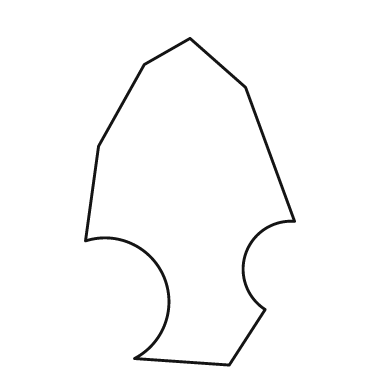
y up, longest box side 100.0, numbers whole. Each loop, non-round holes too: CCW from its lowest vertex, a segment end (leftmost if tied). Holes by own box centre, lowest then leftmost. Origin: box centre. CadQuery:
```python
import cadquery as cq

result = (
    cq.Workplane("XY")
    .moveTo(12.0, -50.0)
    .lineTo(23.0, -33.0)
    .threePointArc((17.0, -16.0), (32.0, -6.0))
    .lineTo(17.0, 35.0)
    .lineTo(0.0, 50.0)
    .lineTo(-14.0, 42.0)
    .lineTo(-28.0, 17.0)
    .lineTo(-32.0, -12.0)
    .threePointArc((-8.0, -23.0), (-17.0, -48.0))
    .close()
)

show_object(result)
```